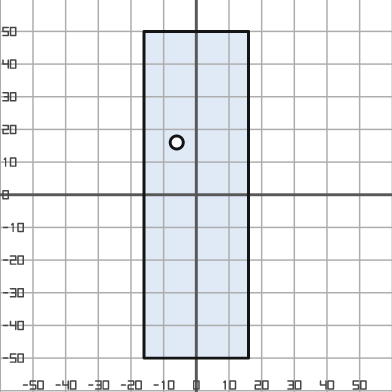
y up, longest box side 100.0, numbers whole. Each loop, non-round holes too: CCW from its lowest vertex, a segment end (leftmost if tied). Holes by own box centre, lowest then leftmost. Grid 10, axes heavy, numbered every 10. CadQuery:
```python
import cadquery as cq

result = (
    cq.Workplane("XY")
    .moveTo(-16.0, -50.0)
    .lineTo(16.0, -50.0)
    .lineTo(16.0, 50.0)
    .lineTo(-16.0, 50.0)
    .close()
    .moveTo(-6.0, 16.0)
    .circle(2.0)
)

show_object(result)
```